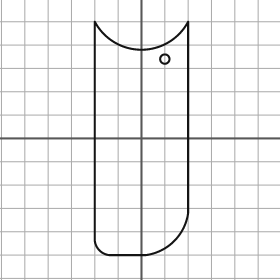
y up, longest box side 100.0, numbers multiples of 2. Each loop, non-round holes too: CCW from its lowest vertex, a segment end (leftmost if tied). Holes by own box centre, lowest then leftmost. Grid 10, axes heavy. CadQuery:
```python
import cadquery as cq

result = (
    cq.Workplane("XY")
    .moveTo(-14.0, -50.0)
    .lineTo(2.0, -50.0)
    .threePointArc((14.0, -44.0), (20.0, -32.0))
    .lineTo(20.0, 50.0)
    .threePointArc((0.0, 38.0), (-20.0, 50.0))
    .lineTo(-20.0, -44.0)
    .threePointArc((-18.0, -48.0), (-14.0, -50.0))
    .close()
    .moveTo(10.0, 34.0)
    .circle(2.0)
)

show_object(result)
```